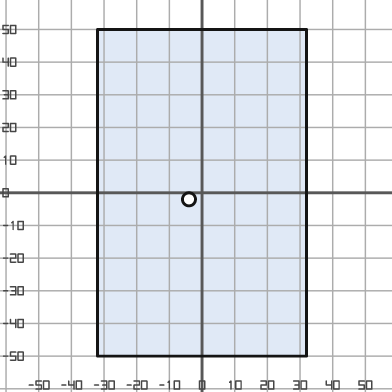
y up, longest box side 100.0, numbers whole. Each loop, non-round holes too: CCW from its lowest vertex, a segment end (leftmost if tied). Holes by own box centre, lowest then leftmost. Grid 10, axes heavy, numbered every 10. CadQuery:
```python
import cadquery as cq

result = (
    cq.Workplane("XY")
    .moveTo(-32.0, -50.0)
    .lineTo(32.0, -50.0)
    .lineTo(32.0, 50.0)
    .lineTo(-32.0, 50.0)
    .close()
    .moveTo(-4.0, -2.0)
    .circle(2.0)
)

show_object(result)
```